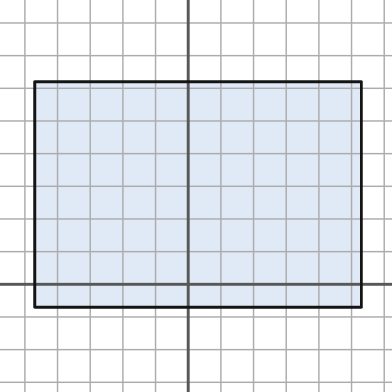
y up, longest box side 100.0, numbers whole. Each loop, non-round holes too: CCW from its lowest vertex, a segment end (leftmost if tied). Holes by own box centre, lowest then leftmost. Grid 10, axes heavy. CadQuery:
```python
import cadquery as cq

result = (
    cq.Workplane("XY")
    .moveTo(-47.0, -7.0)
    .lineTo(53.0, -7.0)
    .lineTo(53.0, 62.0)
    .lineTo(-47.0, 62.0)
    .close()
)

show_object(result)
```